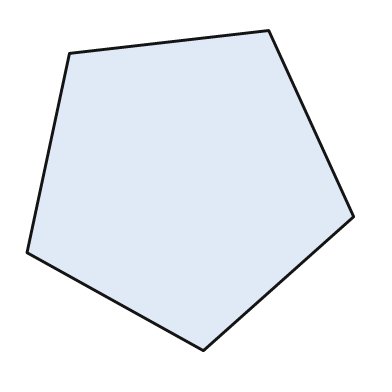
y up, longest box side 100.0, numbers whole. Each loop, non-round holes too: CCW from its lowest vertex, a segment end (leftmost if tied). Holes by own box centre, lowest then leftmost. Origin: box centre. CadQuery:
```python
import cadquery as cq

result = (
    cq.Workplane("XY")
    .moveTo(4.0, -49.0)
    .lineTo(50.0, -8.0)
    .lineTo(24.0, 49.0)
    .lineTo(-37.0, 42.0)
    .lineTo(-50.0, -19.0)
    .close()
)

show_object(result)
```